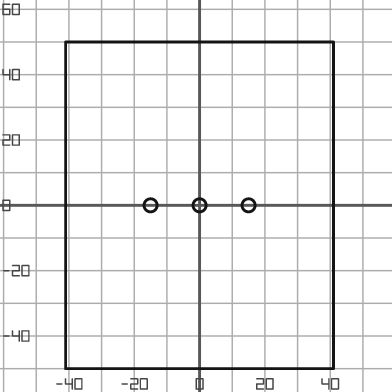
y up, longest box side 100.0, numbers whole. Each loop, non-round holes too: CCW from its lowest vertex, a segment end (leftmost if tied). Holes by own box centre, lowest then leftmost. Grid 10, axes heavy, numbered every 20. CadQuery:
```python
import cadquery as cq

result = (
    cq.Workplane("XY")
    .moveTo(-41.0, -50.0)
    .lineTo(41.0, -50.0)
    .lineTo(41.0, 50.0)
    .lineTo(-41.0, 50.0)
    .close()
    .moveTo(-15.0, 0.0)
    .circle(2.0)
    .moveTo(0.0, 0.0)
    .circle(2.0)
    .moveTo(15.0, 0.0)
    .circle(2.0)
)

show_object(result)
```